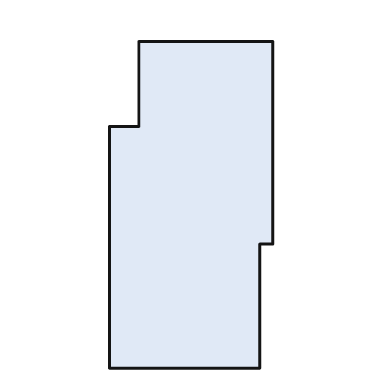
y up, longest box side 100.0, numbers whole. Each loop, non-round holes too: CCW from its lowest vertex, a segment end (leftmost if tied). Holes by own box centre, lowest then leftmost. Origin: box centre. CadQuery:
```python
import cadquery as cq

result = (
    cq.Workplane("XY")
    .moveTo(-25.0, -50.0)
    .lineTo(21.0, -50.0)
    .lineTo(21.0, -12.0)
    .lineTo(25.0, -12.0)
    .lineTo(25.0, 50.0)
    .lineTo(-16.0, 50.0)
    .lineTo(-16.0, 24.0)
    .lineTo(-25.0, 24.0)
    .close()
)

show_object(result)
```